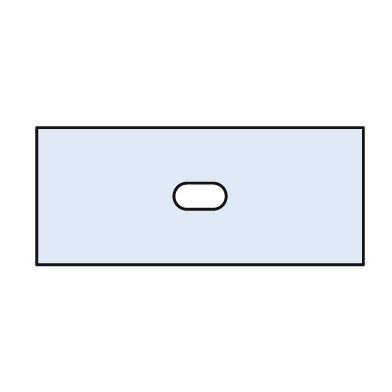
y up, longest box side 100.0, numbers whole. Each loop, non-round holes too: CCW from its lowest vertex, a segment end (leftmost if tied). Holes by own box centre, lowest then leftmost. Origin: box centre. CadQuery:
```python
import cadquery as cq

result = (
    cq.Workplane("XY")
    .moveTo(-50.0, -21.0)
    .lineTo(50.0, -21.0)
    .lineTo(50.0, 21.0)
    .lineTo(-50.0, 21.0)
    .close()
    .moveTo(-4.0, -4.0)
    .lineTo(4.0, -4.0)
    .threePointArc((8.0, 0.0), (4.0, 4.0))
    .lineTo(-4.0, 4.0)
    .threePointArc((-8.0, 0.0), (-4.0, -4.0))
    .close()
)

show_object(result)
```